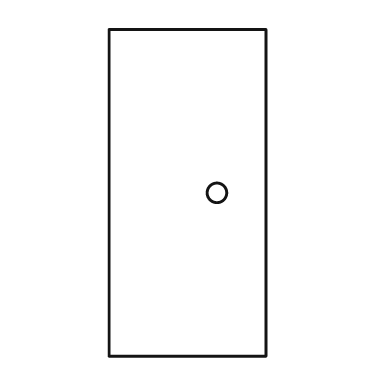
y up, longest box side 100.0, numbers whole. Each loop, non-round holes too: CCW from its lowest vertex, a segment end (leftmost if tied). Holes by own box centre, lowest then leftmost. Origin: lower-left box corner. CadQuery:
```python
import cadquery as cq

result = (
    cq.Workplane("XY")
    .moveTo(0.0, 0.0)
    .lineTo(48.0, 0.0)
    .lineTo(48.0, 100.0)
    .lineTo(0.0, 100.0)
    .close()
    .moveTo(33.0, 50.0)
    .circle(3.0)
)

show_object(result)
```